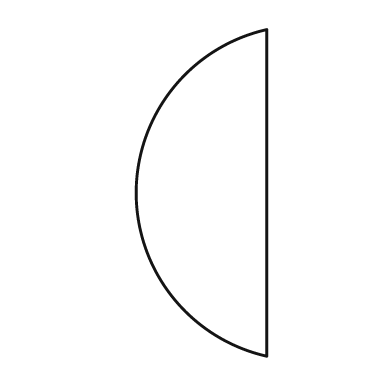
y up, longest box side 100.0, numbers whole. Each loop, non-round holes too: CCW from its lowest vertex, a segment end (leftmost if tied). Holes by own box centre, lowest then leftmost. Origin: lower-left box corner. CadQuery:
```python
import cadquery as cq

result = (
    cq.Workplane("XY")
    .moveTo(40.0, 0.0)
    .lineTo(40.0, 100.0)
    .threePointArc((0.0, 50.0), (40.0, 0.0))
    .close()
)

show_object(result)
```